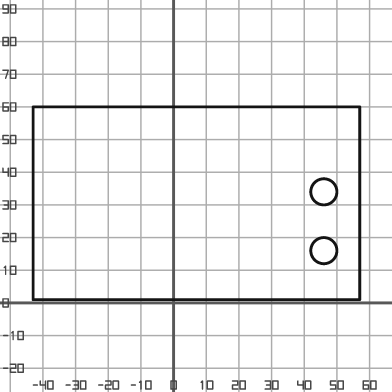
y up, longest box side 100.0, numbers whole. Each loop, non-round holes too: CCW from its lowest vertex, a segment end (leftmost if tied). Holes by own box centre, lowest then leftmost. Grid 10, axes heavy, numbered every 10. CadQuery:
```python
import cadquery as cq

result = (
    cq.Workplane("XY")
    .moveTo(-43.0, 1.0)
    .lineTo(57.0, 1.0)
    .lineTo(57.0, 60.0)
    .lineTo(-43.0, 60.0)
    .close()
    .moveTo(46.0, 16.0)
    .circle(4.0)
    .moveTo(46.0, 34.0)
    .circle(4.0)
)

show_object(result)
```